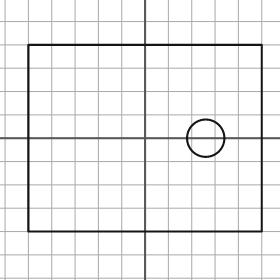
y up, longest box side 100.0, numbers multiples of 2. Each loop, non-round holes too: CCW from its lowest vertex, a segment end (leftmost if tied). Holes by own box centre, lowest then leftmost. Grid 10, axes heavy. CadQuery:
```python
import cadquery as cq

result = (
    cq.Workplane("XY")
    .moveTo(-50.0, -40.0)
    .lineTo(50.0, -40.0)
    .lineTo(50.0, 40.0)
    .lineTo(-50.0, 40.0)
    .close()
    .moveTo(26.0, 0.0)
    .circle(8.0)
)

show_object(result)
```